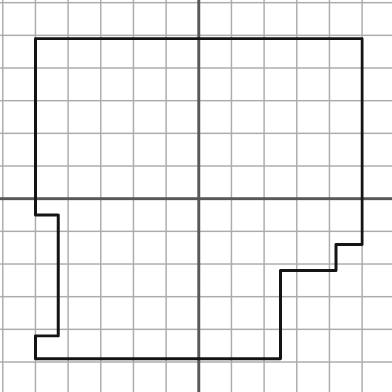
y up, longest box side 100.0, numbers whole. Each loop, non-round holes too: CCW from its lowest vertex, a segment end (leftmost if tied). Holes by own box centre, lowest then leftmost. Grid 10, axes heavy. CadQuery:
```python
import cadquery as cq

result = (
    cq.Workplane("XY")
    .moveTo(-50.0, -49.0)
    .lineTo(25.0, -49.0)
    .lineTo(25.0, -22.0)
    .lineTo(42.0, -22.0)
    .lineTo(42.0, -14.0)
    .lineTo(50.0, -14.0)
    .lineTo(50.0, 49.0)
    .lineTo(-50.0, 49.0)
    .lineTo(-50.0, -5.0)
    .lineTo(-43.0, -5.0)
    .lineTo(-43.0, -42.0)
    .lineTo(-50.0, -42.0)
    .close()
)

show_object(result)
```